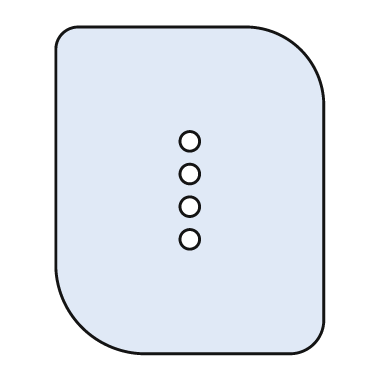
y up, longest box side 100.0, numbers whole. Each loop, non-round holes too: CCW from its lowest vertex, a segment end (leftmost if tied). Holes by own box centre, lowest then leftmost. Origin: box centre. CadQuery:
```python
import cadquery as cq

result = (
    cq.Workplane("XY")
    .moveTo(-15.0, -50.0)
    .lineTo(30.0, -50.0)
    .threePointArc((38.0, -47.0), (41.0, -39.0))
    .lineTo(41.0, 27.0)
    .threePointArc((34.0, 43.0), (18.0, 50.0))
    .lineTo(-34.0, 50.0)
    .threePointArc((-39.0, 48.0), (-41.0, 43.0))
    .lineTo(-41.0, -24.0)
    .threePointArc((-33.0, -42.0), (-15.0, -50.0))
    .close()
    .moveTo(0.0, -15.0)
    .circle(3.0)
    .moveTo(0.0, -5.0)
    .circle(3.0)
    .moveTo(0.0, 5.0)
    .circle(3.0)
    .moveTo(0.0, 15.0)
    .circle(3.0)
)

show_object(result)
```